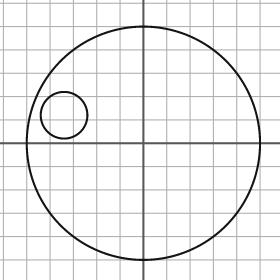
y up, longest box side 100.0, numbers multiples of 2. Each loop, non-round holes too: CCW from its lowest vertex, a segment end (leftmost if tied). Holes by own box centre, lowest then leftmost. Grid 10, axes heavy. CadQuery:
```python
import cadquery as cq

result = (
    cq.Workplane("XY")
    .moveTo(0.0, 0.0)
    .circle(50.0)
    .moveTo(-34.0, 12.0)
    .circle(10.0)
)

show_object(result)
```